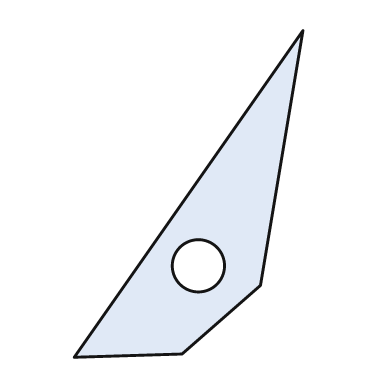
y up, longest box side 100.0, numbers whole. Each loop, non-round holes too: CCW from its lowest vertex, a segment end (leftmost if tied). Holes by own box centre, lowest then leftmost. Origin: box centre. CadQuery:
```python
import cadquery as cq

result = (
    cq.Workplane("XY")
    .moveTo(-35.0, -50.0)
    .lineTo(-2.0, -49.0)
    .lineTo(22.0, -28.0)
    .lineTo(35.0, 50.0)
    .close()
    .moveTo(3.0, -22.0)
    .circle(8.0)
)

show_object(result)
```